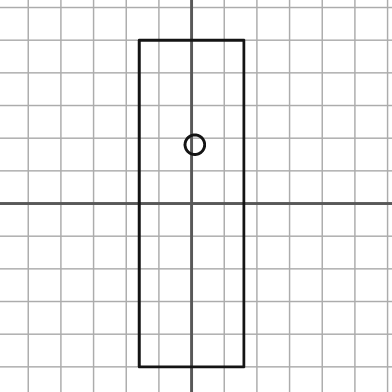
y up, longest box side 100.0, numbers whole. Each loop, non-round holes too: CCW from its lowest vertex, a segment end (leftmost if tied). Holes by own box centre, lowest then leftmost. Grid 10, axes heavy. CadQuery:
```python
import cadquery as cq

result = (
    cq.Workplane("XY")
    .moveTo(-16.0, -50.0)
    .lineTo(16.0, -50.0)
    .lineTo(16.0, 50.0)
    .lineTo(-16.0, 50.0)
    .close()
    .moveTo(1.0, 18.0)
    .circle(3.0)
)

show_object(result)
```